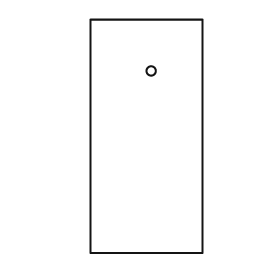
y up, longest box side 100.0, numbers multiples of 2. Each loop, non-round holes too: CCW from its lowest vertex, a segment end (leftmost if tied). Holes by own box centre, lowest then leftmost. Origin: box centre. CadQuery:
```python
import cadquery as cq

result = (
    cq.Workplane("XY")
    .moveTo(-24.0, -50.0)
    .lineTo(24.0, -50.0)
    .lineTo(24.0, 50.0)
    .lineTo(-24.0, 50.0)
    .close()
    .moveTo(2.0, 28.0)
    .circle(2.0)
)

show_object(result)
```